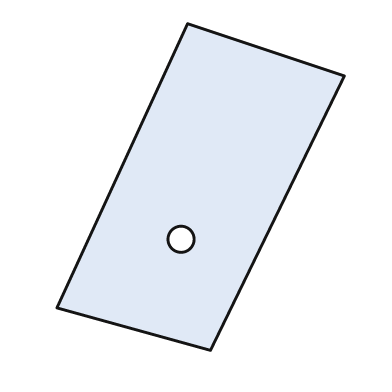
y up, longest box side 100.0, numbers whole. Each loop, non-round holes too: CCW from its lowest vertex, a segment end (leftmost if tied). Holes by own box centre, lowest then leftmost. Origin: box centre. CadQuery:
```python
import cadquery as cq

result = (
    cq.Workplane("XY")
    .moveTo(3.0, -50.0)
    .lineTo(44.0, 34.0)
    .lineTo(-4.0, 50.0)
    .lineTo(-44.0, -37.0)
    .close()
    .moveTo(-6.0, -16.0)
    .circle(4.0)
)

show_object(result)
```